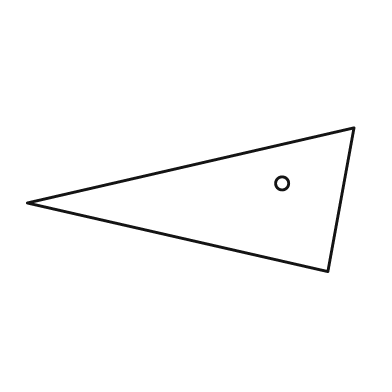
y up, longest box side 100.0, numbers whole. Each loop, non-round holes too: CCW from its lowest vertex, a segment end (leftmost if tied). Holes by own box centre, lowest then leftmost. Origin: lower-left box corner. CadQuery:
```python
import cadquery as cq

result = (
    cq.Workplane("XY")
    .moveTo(92.0, 0.0)
    .lineTo(100.0, 44.0)
    .lineTo(0.0, 21.0)
    .close()
    .moveTo(78.0, 27.0)
    .circle(2.0)
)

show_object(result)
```